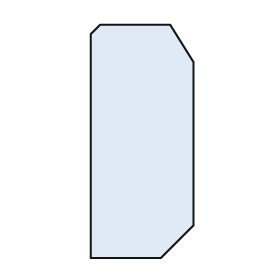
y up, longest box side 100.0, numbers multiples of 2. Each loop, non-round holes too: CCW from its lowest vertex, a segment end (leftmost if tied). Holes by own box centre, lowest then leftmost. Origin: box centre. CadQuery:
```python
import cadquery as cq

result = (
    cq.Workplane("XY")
    .moveTo(-22.0, -50.0)
    .lineTo(8.0, -50.0)
    .lineTo(22.0, -36.0)
    .lineTo(22.0, 34.0)
    .lineTo(12.0, 50.0)
    .lineTo(-18.0, 50.0)
    .lineTo(-22.0, 46.0)
    .close()
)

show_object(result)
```